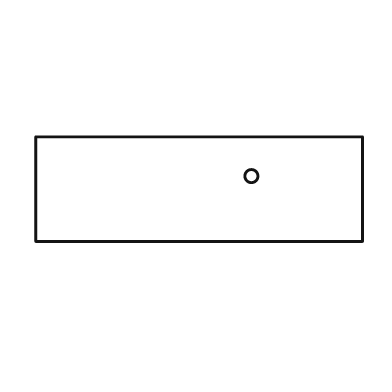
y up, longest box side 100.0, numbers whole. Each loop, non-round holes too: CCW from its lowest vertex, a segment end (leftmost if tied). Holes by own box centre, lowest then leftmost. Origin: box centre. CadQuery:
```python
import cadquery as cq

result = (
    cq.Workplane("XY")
    .moveTo(-50.0, -16.0)
    .lineTo(50.0, -16.0)
    .lineTo(50.0, 16.0)
    .lineTo(-50.0, 16.0)
    .close()
    .moveTo(16.0, 4.0)
    .circle(2.0)
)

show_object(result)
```